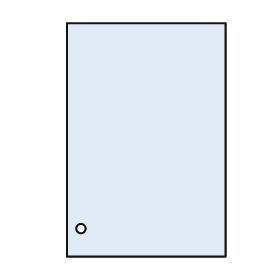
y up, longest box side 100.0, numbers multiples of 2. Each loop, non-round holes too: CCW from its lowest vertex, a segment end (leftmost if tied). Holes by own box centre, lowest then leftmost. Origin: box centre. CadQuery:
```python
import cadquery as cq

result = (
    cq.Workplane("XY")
    .moveTo(-34.0, -50.0)
    .lineTo(34.0, -50.0)
    .lineTo(34.0, 50.0)
    .lineTo(-34.0, 50.0)
    .close()
    .moveTo(-28.0, -38.0)
    .circle(2.0)
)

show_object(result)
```